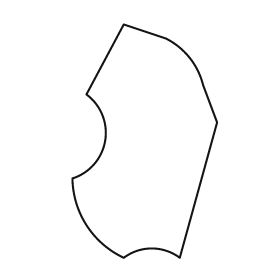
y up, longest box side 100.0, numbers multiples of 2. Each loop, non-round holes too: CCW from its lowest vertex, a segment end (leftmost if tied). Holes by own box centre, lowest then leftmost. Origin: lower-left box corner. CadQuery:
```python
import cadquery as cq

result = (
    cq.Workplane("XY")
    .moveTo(22.0, 0.0)
    .threePointArc((34.0, 4.0), (46.0, 0.0))
    .lineTo(62.0, 58.0)
    .lineTo(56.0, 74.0)
    .threePointArc((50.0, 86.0), (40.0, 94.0))
    .lineTo(22.0, 100.0)
    .lineTo(6.0, 70.0)
    .threePointArc((14.0, 50.0), (0.0, 34.0))
    .threePointArc((6.0, 14.0), (22.0, 0.0))
    .close()
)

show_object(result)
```